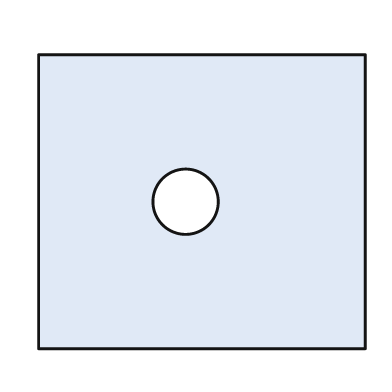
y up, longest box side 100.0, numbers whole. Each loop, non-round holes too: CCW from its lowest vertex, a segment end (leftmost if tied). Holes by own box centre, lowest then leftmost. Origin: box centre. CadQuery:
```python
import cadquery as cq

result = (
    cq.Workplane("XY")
    .moveTo(-50.0, -45.0)
    .lineTo(50.0, -45.0)
    .lineTo(50.0, 45.0)
    .lineTo(-50.0, 45.0)
    .close()
    .moveTo(-5.0, 0.0)
    .circle(10.0)
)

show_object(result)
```